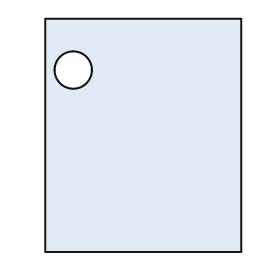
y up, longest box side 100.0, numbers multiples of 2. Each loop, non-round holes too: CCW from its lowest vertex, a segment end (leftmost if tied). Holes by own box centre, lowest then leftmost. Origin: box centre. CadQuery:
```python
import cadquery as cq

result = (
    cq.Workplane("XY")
    .moveTo(-42.0, -50.0)
    .lineTo(42.0, -50.0)
    .lineTo(42.0, 50.0)
    .lineTo(-42.0, 50.0)
    .close()
    .moveTo(-30.0, 28.0)
    .circle(8.0)
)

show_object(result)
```